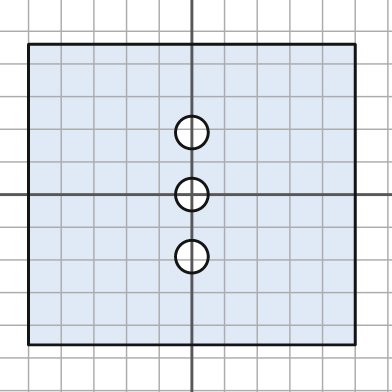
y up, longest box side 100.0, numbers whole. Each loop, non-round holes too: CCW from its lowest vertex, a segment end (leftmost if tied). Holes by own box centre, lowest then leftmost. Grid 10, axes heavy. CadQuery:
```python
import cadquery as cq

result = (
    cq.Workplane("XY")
    .moveTo(-50.0, -46.0)
    .lineTo(50.0, -46.0)
    .lineTo(50.0, 46.0)
    .lineTo(-50.0, 46.0)
    .close()
    .moveTo(0.0, -19.0)
    .circle(5.0)
    .moveTo(0.0, 0.0)
    .circle(5.0)
    .moveTo(0.0, 19.0)
    .circle(5.0)
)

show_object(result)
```